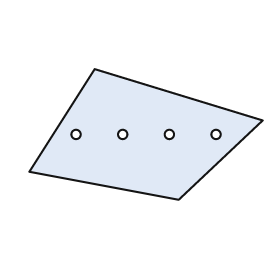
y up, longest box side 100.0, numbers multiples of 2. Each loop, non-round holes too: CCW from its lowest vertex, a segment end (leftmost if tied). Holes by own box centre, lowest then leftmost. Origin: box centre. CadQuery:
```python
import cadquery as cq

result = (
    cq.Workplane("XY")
    .moveTo(14.0, -28.0)
    .lineTo(50.0, 6.0)
    .lineTo(-22.0, 28.0)
    .lineTo(-50.0, -16.0)
    .close()
    .moveTo(-30.0, 0.0)
    .circle(2.0)
    .moveTo(-10.0, 0.0)
    .circle(2.0)
    .moveTo(10.0, 0.0)
    .circle(2.0)
    .moveTo(30.0, 0.0)
    .circle(2.0)
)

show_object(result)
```